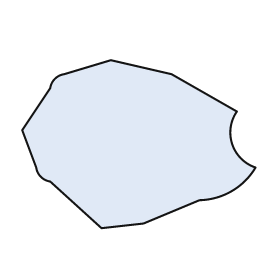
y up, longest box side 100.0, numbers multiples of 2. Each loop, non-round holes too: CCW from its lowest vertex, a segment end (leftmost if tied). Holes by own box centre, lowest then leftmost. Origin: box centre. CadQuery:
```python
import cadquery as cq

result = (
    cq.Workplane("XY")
    .moveTo(-16.0, -36.0)
    .lineTo(2.0, -34.0)
    .lineTo(26.0, -24.0)
    .threePointArc((40.0, -20.0), (50.0, -10.0))
    .threePointArc((40.0, 0.0), (42.0, 14.0))
    .lineTo(14.0, 30.0)
    .lineTo(-12.0, 36.0)
    .lineTo(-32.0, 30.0)
    .threePointArc((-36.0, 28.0), (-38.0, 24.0))
    .lineTo(-50.0, 6.0)
    .lineTo(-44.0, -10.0)
    .threePointArc((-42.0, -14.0), (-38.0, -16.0))
    .close()
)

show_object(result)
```